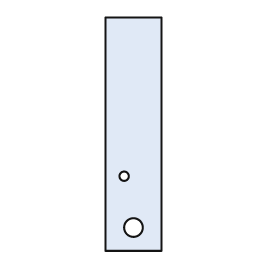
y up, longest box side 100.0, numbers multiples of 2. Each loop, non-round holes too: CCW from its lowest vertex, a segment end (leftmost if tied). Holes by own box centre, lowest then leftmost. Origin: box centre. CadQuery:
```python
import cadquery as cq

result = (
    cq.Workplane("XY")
    .moveTo(-12.0, -50.0)
    .lineTo(12.0, -50.0)
    .lineTo(12.0, 50.0)
    .lineTo(-12.0, 50.0)
    .close()
    .moveTo(0.0, -40.0)
    .circle(4.0)
    .moveTo(-4.0, -18.0)
    .circle(2.0)
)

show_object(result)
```